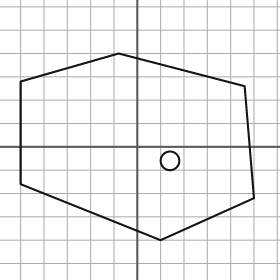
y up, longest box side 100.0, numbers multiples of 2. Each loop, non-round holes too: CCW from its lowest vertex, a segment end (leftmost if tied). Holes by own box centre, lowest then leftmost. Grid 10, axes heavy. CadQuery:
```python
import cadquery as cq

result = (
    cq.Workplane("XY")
    .moveTo(10.0, -40.0)
    .lineTo(50.0, -22.0)
    .lineTo(46.0, 26.0)
    .lineTo(-8.0, 40.0)
    .lineTo(-50.0, 28.0)
    .lineTo(-50.0, -16.0)
    .close()
    .moveTo(14.0, -6.0)
    .circle(4.0)
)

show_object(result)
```